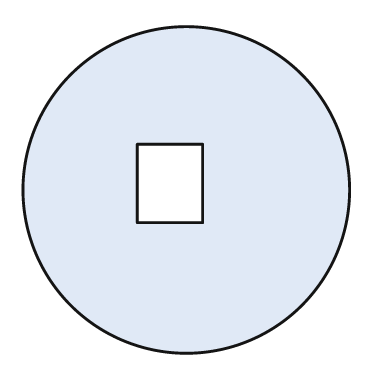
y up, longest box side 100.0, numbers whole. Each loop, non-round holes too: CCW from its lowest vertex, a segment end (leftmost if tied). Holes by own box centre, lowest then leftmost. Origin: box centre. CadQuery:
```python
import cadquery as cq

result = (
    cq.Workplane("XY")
    .moveTo(0.0, 0.0)
    .circle(50.0)
    .moveTo(-15.0, -10.0)
    .lineTo(5.0, -10.0)
    .lineTo(5.0, 14.0)
    .lineTo(-15.0, 14.0)
    .close()
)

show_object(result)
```